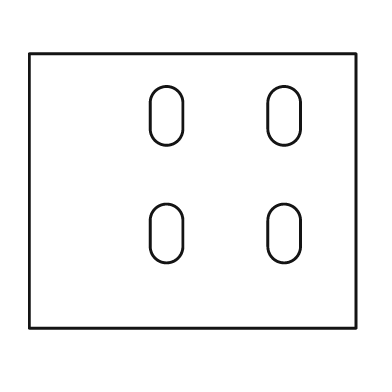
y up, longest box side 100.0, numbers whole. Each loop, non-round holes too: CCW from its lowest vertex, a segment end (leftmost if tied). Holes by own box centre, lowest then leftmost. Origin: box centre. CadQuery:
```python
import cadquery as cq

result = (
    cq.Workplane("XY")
    .moveTo(-50.0, -42.0)
    .lineTo(50.0, -42.0)
    .lineTo(50.0, 42.0)
    .lineTo(-50.0, 42.0)
    .close()
    .moveTo(-13.0, -17.0)
    .threePointArc((-8.0, -22.0), (-3.0, -17.0))
    .lineTo(-3.0, -9.0)
    .threePointArc((-8.0, -4.0), (-13.0, -9.0))
    .close()
    .moveTo(23.0, -17.0)
    .threePointArc((28.0, -22.0), (33.0, -17.0))
    .lineTo(33.0, -9.0)
    .threePointArc((28.0, -4.0), (23.0, -9.0))
    .close()
    .moveTo(-13.0, 19.0)
    .threePointArc((-8.0, 14.0), (-3.0, 19.0))
    .lineTo(-3.0, 27.0)
    .threePointArc((-8.0, 32.0), (-13.0, 27.0))
    .close()
    .moveTo(23.0, 19.0)
    .threePointArc((28.0, 14.0), (33.0, 19.0))
    .lineTo(33.0, 27.0)
    .threePointArc((28.0, 32.0), (23.0, 27.0))
    .close()
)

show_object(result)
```